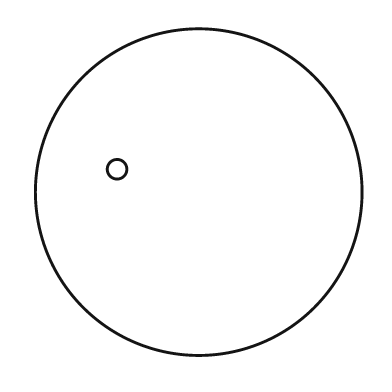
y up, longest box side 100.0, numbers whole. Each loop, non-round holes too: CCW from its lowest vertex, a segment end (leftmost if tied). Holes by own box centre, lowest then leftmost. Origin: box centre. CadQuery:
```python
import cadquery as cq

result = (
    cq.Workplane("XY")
    .moveTo(0.0, 0.0)
    .circle(50.0)
    .moveTo(-25.0, 7.0)
    .circle(3.0)
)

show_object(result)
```